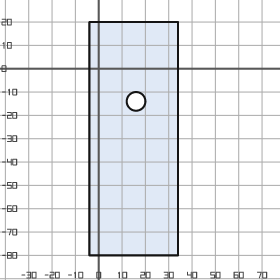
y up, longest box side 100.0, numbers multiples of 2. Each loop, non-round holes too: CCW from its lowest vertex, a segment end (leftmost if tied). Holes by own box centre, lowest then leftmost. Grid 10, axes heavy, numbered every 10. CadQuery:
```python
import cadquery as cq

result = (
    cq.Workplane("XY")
    .moveTo(-4.0, -80.0)
    .lineTo(34.0, -80.0)
    .lineTo(34.0, 20.0)
    .lineTo(-4.0, 20.0)
    .close()
    .moveTo(16.0, -14.0)
    .circle(4.0)
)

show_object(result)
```